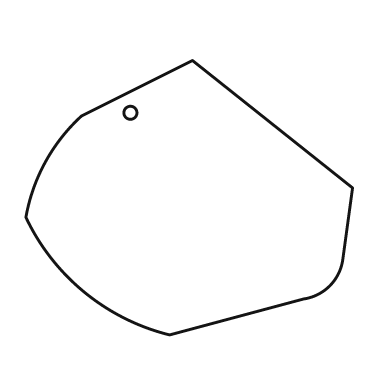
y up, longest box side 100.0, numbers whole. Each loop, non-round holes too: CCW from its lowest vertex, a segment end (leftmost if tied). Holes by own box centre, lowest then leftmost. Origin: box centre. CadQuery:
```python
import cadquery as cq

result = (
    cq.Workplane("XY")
    .moveTo(-6.0, -42.0)
    .lineTo(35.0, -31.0)
    .threePointArc((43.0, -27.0), (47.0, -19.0))
    .lineTo(50.0, 3.0)
    .lineTo(1.0, 42.0)
    .lineTo(-33.0, 25.0)
    .threePointArc((-44.0, 11.0), (-50.0, -6.0))
    .threePointArc((-32.0, -29.0), (-6.0, -42.0))
    .close()
    .moveTo(-18.0, 26.0)
    .circle(2.0)
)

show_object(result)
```